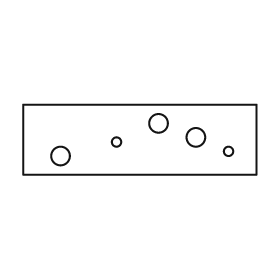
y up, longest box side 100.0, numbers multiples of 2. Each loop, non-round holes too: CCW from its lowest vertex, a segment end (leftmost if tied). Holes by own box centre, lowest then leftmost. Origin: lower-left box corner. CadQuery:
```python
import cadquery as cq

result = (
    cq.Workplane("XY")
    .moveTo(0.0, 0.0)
    .lineTo(100.0, 0.0)
    .lineTo(100.0, 30.0)
    .lineTo(0.0, 30.0)
    .close()
    .moveTo(16.0, 8.0)
    .circle(4.0)
    .moveTo(88.0, 10.0)
    .circle(2.0)
    .moveTo(40.0, 14.0)
    .circle(2.0)
    .moveTo(74.0, 16.0)
    .circle(4.0)
    .moveTo(58.0, 22.0)
    .circle(4.0)
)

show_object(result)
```